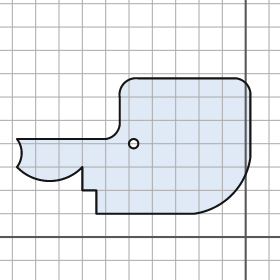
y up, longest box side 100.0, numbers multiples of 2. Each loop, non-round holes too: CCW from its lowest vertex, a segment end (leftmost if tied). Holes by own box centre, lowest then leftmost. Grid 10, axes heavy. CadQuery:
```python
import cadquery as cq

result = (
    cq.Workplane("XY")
    .moveTo(-64.0, 10.0)
    .lineTo(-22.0, 10.0)
    .threePointArc((-6.0, 18.0), (2.0, 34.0))
    .lineTo(2.0, 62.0)
    .threePointArc((0.0, 66.0), (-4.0, 68.0))
    .lineTo(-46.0, 68.0)
    .threePointArc((-52.0, 66.0), (-54.0, 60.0))
    .lineTo(-54.0, 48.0)
    .threePointArc((-56.0, 44.0), (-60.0, 42.0))
    .lineTo(-98.0, 42.0)
    .threePointArc((-96.0, 36.0), (-98.0, 30.0))
    .threePointArc((-84.0, 24.0), (-70.0, 30.0))
    .lineTo(-70.0, 20.0)
    .lineTo(-64.0, 20.0)
    .close()
    .moveTo(-48.0, 40.0)
    .circle(2.0)
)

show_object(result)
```